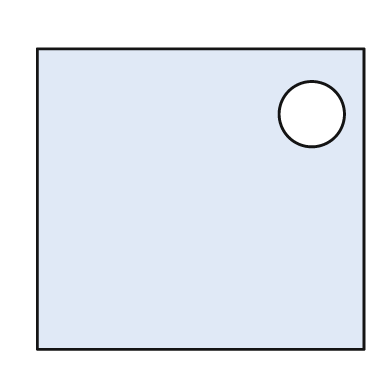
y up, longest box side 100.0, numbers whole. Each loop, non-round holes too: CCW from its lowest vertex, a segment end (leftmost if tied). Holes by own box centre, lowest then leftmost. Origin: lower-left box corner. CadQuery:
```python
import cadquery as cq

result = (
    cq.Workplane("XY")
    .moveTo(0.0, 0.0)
    .lineTo(100.0, 0.0)
    .lineTo(100.0, 92.0)
    .lineTo(0.0, 92.0)
    .close()
    .moveTo(84.0, 72.0)
    .circle(10.0)
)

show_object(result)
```